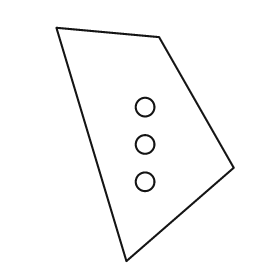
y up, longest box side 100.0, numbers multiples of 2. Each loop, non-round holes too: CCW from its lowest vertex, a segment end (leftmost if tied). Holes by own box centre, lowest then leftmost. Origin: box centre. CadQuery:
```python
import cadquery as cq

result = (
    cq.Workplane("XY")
    .moveTo(-8.0, -50.0)
    .lineTo(38.0, -10.0)
    .lineTo(6.0, 46.0)
    .lineTo(-38.0, 50.0)
    .close()
    .moveTo(0.0, -16.0)
    .circle(4.0)
    .moveTo(0.0, 0.0)
    .circle(4.0)
    .moveTo(0.0, 16.0)
    .circle(4.0)
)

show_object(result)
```